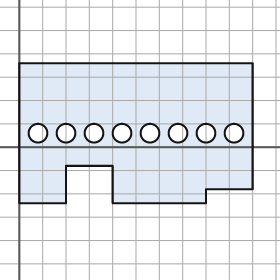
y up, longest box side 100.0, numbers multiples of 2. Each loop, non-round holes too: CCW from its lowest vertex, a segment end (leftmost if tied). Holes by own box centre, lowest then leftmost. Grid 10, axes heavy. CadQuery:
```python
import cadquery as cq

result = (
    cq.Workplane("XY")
    .moveTo(0.0, -24.0)
    .lineTo(20.0, -24.0)
    .lineTo(20.0, -8.0)
    .lineTo(40.0, -8.0)
    .lineTo(40.0, -24.0)
    .lineTo(80.0, -24.0)
    .lineTo(80.0, -18.0)
    .lineTo(100.0, -18.0)
    .lineTo(100.0, 36.0)
    .lineTo(0.0, 36.0)
    .close()
    .moveTo(8.0, 6.0)
    .circle(4.0)
    .moveTo(20.0, 6.0)
    .circle(4.0)
    .moveTo(32.0, 6.0)
    .circle(4.0)
    .moveTo(44.0, 6.0)
    .circle(4.0)
    .moveTo(56.0, 6.0)
    .circle(4.0)
    .moveTo(68.0, 6.0)
    .circle(4.0)
    .moveTo(80.0, 6.0)
    .circle(4.0)
    .moveTo(92.0, 6.0)
    .circle(4.0)
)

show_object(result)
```